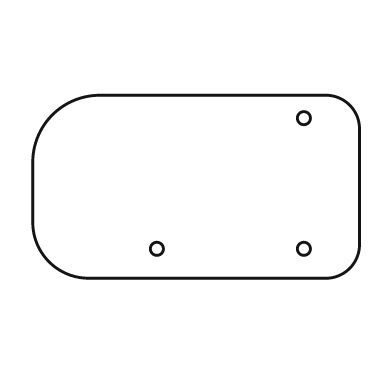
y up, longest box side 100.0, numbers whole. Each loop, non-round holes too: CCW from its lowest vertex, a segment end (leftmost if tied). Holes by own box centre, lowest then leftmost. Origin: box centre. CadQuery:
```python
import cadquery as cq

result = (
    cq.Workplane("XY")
    .moveTo(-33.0, -28.0)
    .lineTo(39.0, -28.0)
    .threePointArc((47.0, -25.0), (50.0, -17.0))
    .lineTo(50.0, 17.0)
    .threePointArc((47.0, 25.0), (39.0, 28.0))
    .lineTo(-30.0, 28.0)
    .threePointArc((-44.0, 22.0), (-50.0, 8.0))
    .lineTo(-50.0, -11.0)
    .threePointArc((-45.0, -23.0), (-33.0, -28.0))
    .close()
    .moveTo(-12.0, -19.0)
    .circle(2.0)
    .moveTo(33.0, -19.0)
    .circle(2.0)
    .moveTo(33.0, 21.0)
    .circle(2.0)
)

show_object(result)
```